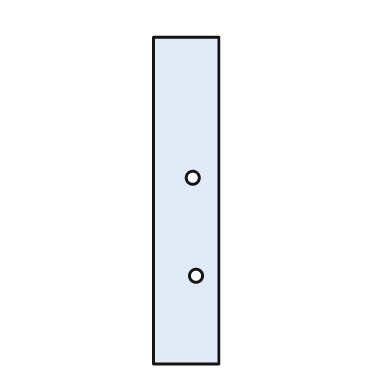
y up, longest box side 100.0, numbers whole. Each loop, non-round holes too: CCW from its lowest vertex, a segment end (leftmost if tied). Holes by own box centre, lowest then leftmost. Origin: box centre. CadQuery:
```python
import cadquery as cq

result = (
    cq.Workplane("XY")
    .moveTo(-10.0, -50.0)
    .lineTo(10.0, -50.0)
    .lineTo(10.0, 50.0)
    .lineTo(-10.0, 50.0)
    .close()
    .moveTo(3.0, -23.0)
    .circle(2.0)
    .moveTo(2.0, 7.0)
    .circle(2.0)
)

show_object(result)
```